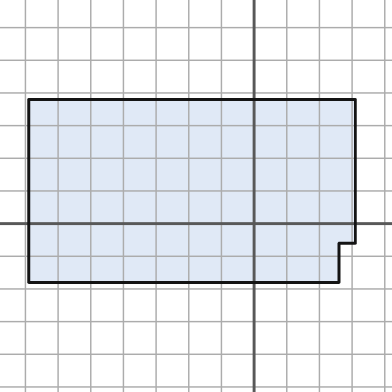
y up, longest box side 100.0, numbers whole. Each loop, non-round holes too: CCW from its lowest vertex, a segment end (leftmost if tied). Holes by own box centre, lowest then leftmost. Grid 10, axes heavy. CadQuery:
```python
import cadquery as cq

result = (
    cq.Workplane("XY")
    .moveTo(-69.0, -18.0)
    .lineTo(26.0, -18.0)
    .lineTo(26.0, -6.0)
    .lineTo(31.0, -6.0)
    .lineTo(31.0, 38.0)
    .lineTo(-69.0, 38.0)
    .close()
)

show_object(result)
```